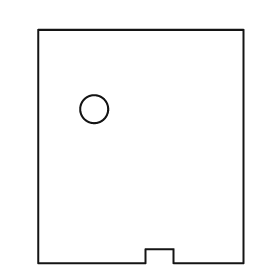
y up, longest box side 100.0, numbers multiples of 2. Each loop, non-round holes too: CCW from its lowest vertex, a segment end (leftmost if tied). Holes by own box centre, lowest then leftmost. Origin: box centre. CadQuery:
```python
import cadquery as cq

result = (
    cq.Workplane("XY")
    .moveTo(-44.0, -50.0)
    .lineTo(2.0, -50.0)
    .lineTo(2.0, -44.0)
    .lineTo(14.0, -44.0)
    .lineTo(14.0, -50.0)
    .lineTo(44.0, -50.0)
    .lineTo(44.0, 50.0)
    .lineTo(-44.0, 50.0)
    .close()
    .moveTo(-20.0, 16.0)
    .circle(6.0)
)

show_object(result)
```